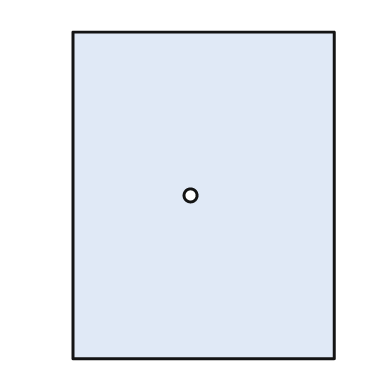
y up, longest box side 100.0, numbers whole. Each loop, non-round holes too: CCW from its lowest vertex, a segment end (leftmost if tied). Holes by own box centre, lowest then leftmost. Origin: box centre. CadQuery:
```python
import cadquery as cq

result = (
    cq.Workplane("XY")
    .moveTo(-40.0, -50.0)
    .lineTo(40.0, -50.0)
    .lineTo(40.0, 50.0)
    .lineTo(-40.0, 50.0)
    .close()
    .moveTo(-4.0, 0.0)
    .circle(2.0)
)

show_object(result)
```